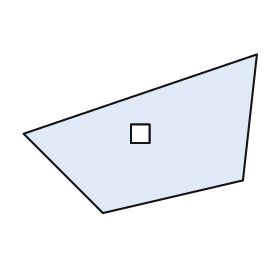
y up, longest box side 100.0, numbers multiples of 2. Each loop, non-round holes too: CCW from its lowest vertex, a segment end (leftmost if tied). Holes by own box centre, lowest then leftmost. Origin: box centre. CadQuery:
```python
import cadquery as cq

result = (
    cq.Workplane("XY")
    .moveTo(-16.0, -34.0)
    .lineTo(44.0, -20.0)
    .lineTo(50.0, 34.0)
    .lineTo(-50.0, 0.0)
    .close()
    .moveTo(-4.0, -4.0)
    .lineTo(4.0, -4.0)
    .lineTo(4.0, 4.0)
    .lineTo(-4.0, 4.0)
    .close()
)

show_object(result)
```